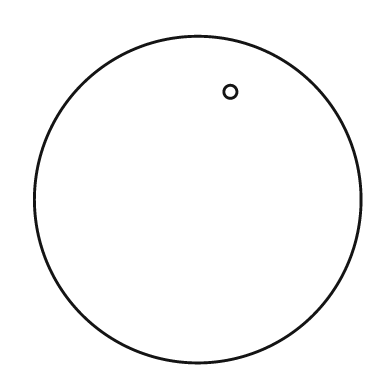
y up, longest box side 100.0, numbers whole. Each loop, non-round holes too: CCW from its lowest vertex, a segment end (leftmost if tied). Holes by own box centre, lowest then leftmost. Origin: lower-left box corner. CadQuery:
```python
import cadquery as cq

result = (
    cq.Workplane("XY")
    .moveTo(50.0, 50.0)
    .circle(50.0)
    .moveTo(60.0, 83.0)
    .circle(2.0)
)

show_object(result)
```